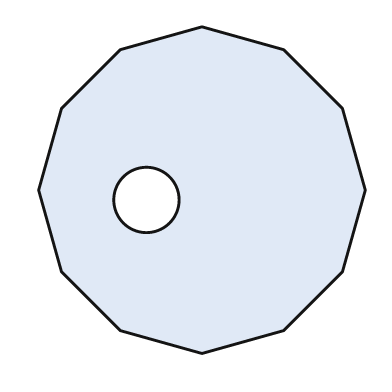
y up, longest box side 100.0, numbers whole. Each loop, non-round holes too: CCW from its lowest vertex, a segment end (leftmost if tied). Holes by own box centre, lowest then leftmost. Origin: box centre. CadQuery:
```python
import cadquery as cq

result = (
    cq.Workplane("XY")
    .moveTo(0.0, -50.0)
    .lineTo(25.0, -43.0)
    .lineTo(43.0, -25.0)
    .lineTo(50.0, 0.0)
    .lineTo(43.0, 25.0)
    .lineTo(25.0, 43.0)
    .lineTo(0.0, 50.0)
    .lineTo(-25.0, 43.0)
    .lineTo(-43.0, 25.0)
    .lineTo(-50.0, 0.0)
    .lineTo(-43.0, -25.0)
    .lineTo(-25.0, -43.0)
    .close()
    .moveTo(-17.0, -3.0)
    .circle(10.0)
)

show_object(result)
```